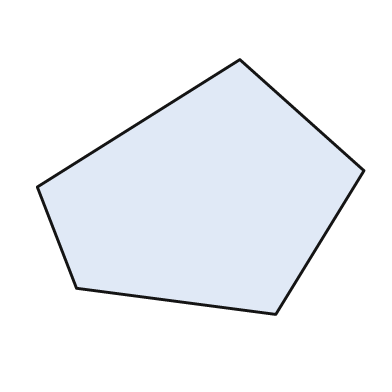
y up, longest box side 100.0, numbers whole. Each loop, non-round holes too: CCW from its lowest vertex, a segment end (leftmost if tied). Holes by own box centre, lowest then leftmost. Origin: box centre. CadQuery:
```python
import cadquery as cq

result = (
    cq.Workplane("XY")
    .moveTo(23.0, -39.0)
    .lineTo(50.0, 5.0)
    .lineTo(12.0, 39.0)
    .lineTo(-50.0, 0.0)
    .lineTo(-38.0, -31.0)
    .close()
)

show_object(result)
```